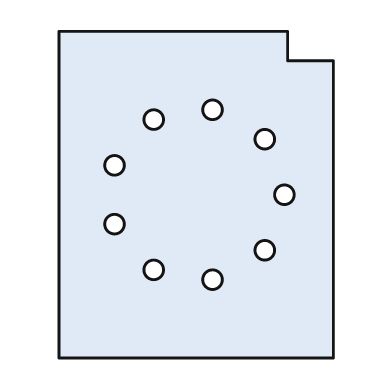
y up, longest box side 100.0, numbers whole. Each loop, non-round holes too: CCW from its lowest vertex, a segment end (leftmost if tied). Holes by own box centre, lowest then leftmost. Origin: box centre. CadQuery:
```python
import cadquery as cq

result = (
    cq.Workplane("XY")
    .moveTo(-42.0, -50.0)
    .lineTo(42.0, -50.0)
    .lineTo(42.0, 41.0)
    .lineTo(28.0, 41.0)
    .lineTo(28.0, 50.0)
    .lineTo(-42.0, 50.0)
    .close()
    .moveTo(5.0, -26.0)
    .circle(3.0)
    .moveTo(-13.0, -23.0)
    .circle(3.0)
    .moveTo(21.0, -17.0)
    .circle(3.0)
    .moveTo(-25.0, -9.0)
    .circle(3.0)
    .moveTo(27.0, 0.0)
    .circle(3.0)
    .moveTo(-25.0, 9.0)
    .circle(3.0)
    .moveTo(21.0, 17.0)
    .circle(3.0)
    .moveTo(-13.0, 23.0)
    .circle(3.0)
    .moveTo(5.0, 26.0)
    .circle(3.0)
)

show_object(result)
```